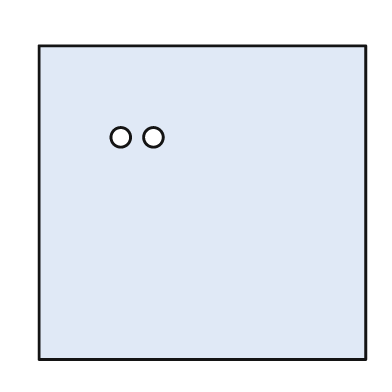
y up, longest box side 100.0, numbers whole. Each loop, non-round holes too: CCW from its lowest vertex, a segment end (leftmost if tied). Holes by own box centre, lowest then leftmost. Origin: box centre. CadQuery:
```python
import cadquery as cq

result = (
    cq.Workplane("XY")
    .moveTo(-50.0, -48.0)
    .lineTo(50.0, -48.0)
    .lineTo(50.0, 48.0)
    .lineTo(-50.0, 48.0)
    .close()
    .moveTo(-25.0, 20.0)
    .circle(3.0)
    .moveTo(-15.0, 20.0)
    .circle(3.0)
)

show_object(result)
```